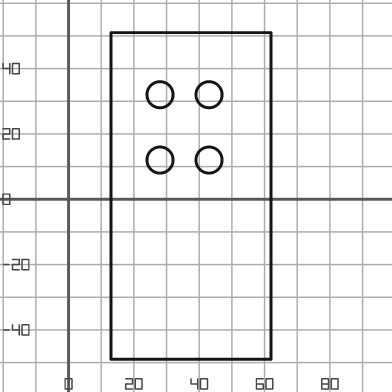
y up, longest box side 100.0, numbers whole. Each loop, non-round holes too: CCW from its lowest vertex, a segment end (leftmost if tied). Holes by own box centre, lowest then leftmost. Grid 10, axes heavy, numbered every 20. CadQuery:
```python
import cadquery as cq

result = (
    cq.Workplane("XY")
    .moveTo(13.0, -49.0)
    .lineTo(62.0, -49.0)
    .lineTo(62.0, 51.0)
    .lineTo(13.0, 51.0)
    .close()
    .moveTo(28.0, 12.0)
    .circle(4.0)
    .moveTo(43.0, 12.0)
    .circle(4.0)
    .moveTo(28.0, 32.0)
    .circle(4.0)
    .moveTo(43.0, 32.0)
    .circle(4.0)
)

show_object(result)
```